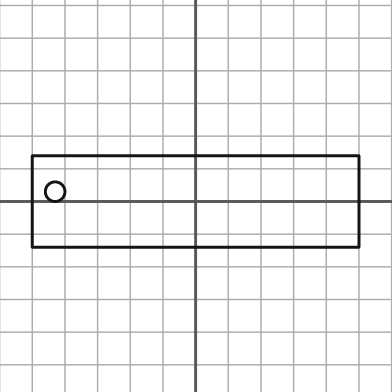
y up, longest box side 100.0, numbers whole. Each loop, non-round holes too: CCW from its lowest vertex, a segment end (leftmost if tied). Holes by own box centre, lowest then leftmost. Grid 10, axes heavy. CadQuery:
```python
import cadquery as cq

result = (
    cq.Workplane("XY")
    .moveTo(-50.0, -14.0)
    .lineTo(50.0, -14.0)
    .lineTo(50.0, 14.0)
    .lineTo(-50.0, 14.0)
    .close()
    .moveTo(-43.0, 3.0)
    .circle(3.0)
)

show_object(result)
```